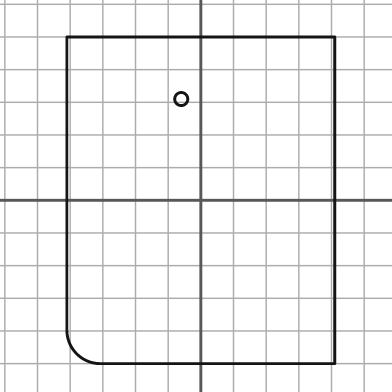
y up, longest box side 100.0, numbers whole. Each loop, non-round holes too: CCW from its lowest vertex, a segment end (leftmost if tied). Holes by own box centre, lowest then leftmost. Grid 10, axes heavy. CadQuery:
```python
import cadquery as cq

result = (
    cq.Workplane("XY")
    .moveTo(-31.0, -50.0)
    .lineTo(41.0, -50.0)
    .lineTo(41.0, 50.0)
    .lineTo(-41.0, 50.0)
    .lineTo(-41.0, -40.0)
    .threePointArc((-38.0, -47.0), (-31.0, -50.0))
    .close()
    .moveTo(-6.0, 31.0)
    .circle(2.0)
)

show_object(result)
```